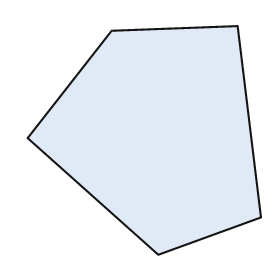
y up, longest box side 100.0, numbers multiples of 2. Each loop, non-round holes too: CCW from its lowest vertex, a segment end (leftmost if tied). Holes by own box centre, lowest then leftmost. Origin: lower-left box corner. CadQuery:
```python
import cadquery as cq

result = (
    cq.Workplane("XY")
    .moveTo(56.0, 0.0)
    .lineTo(100.0, 16.0)
    .lineTo(90.0, 98.0)
    .lineTo(36.0, 96.0)
    .lineTo(0.0, 50.0)
    .close()
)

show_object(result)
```